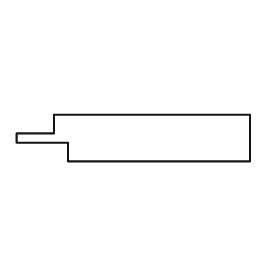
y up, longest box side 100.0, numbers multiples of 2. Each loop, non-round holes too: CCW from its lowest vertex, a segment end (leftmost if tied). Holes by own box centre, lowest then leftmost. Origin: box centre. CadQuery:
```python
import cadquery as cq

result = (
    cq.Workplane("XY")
    .moveTo(-28.0, -10.0)
    .lineTo(50.0, -10.0)
    .lineTo(50.0, 10.0)
    .lineTo(-34.0, 10.0)
    .lineTo(-34.0, 2.0)
    .lineTo(-50.0, 2.0)
    .lineTo(-50.0, -2.0)
    .lineTo(-28.0, -2.0)
    .close()
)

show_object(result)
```